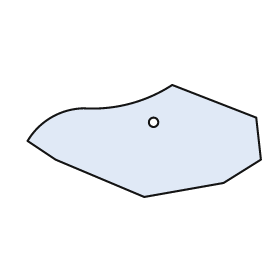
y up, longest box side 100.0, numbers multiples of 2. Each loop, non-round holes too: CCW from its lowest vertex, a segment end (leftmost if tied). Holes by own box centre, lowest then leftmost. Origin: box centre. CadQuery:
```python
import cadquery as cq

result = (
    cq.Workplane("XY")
    .moveTo(0.0, -24.0)
    .lineTo(34.0, -18.0)
    .lineTo(50.0, -8.0)
    .lineTo(48.0, 10.0)
    .lineTo(12.0, 24.0)
    .threePointArc((-6.0, 16.0), (-26.0, 14.0))
    .threePointArc((-40.0, 10.0), (-50.0, 0.0))
    .lineTo(-38.0, -8.0)
    .close()
    .moveTo(4.0, 8.0)
    .circle(2.0)
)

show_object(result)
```